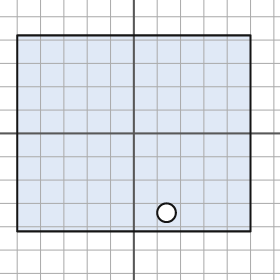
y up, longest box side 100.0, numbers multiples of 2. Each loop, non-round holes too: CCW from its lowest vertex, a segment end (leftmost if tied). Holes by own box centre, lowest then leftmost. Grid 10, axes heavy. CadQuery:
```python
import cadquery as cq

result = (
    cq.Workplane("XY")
    .moveTo(-50.0, -42.0)
    .lineTo(50.0, -42.0)
    .lineTo(50.0, 42.0)
    .lineTo(-50.0, 42.0)
    .close()
    .moveTo(14.0, -34.0)
    .circle(4.0)
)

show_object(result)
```